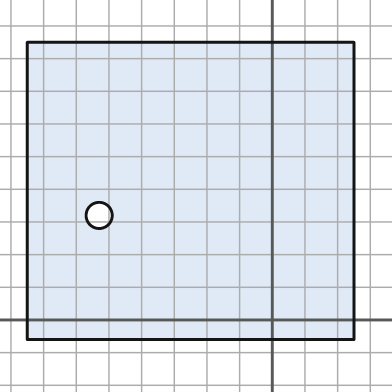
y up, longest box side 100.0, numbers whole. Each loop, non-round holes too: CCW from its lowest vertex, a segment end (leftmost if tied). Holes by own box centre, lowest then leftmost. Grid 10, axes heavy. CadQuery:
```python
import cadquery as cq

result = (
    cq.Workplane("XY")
    .moveTo(-75.0, -6.0)
    .lineTo(25.0, -6.0)
    .lineTo(25.0, 85.0)
    .lineTo(-75.0, 85.0)
    .close()
    .moveTo(-53.0, 32.0)
    .circle(4.0)
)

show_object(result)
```